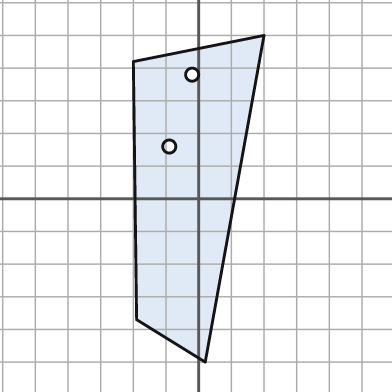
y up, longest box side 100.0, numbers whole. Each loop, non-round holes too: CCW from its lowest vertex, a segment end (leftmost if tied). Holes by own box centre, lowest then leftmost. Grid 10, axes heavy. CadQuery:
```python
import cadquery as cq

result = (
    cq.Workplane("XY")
    .moveTo(2.0, -50.0)
    .lineTo(20.0, 50.0)
    .lineTo(-20.0, 42.0)
    .lineTo(-19.0, -37.0)
    .close()
    .moveTo(-9.0, 16.0)
    .circle(2.0)
    .moveTo(-2.0, 38.0)
    .circle(2.0)
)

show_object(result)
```